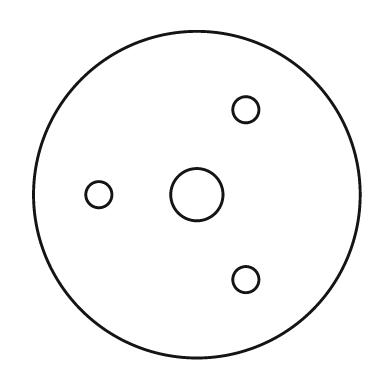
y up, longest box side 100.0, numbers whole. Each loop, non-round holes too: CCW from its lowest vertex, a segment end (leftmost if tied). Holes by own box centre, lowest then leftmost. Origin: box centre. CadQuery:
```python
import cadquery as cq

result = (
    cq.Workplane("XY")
    .moveTo(0.0, 0.0)
    .circle(50.0)
    .moveTo(15.0, -26.0)
    .circle(4.0)
    .moveTo(-30.0, 0.0)
    .circle(4.0)
    .moveTo(0.0, 0.0)
    .circle(8.0)
    .moveTo(15.0, 26.0)
    .circle(4.0)
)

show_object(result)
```